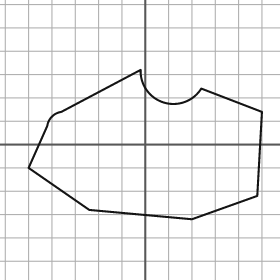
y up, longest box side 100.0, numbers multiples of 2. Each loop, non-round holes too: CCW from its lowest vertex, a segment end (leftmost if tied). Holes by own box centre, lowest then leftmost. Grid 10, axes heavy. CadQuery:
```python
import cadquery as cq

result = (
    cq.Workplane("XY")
    .moveTo(20.0, -32.0)
    .lineTo(48.0, -22.0)
    .lineTo(50.0, 14.0)
    .lineTo(24.0, 24.0)
    .threePointArc((8.0, 18.0), (-2.0, 32.0))
    .lineTo(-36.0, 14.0)
    .threePointArc((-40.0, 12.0), (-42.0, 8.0))
    .lineTo(-50.0, -10.0)
    .lineTo(-24.0, -28.0)
    .close()
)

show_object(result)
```